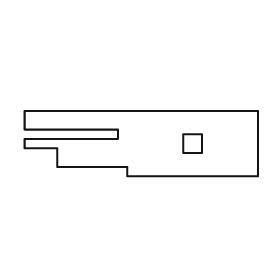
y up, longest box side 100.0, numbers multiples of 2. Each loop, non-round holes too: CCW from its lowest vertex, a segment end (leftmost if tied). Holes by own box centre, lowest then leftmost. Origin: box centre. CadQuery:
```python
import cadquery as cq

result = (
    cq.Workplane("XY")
    .moveTo(-6.0, -14.0)
    .lineTo(50.0, -14.0)
    .lineTo(50.0, 14.0)
    .lineTo(-50.0, 14.0)
    .lineTo(-50.0, 6.0)
    .lineTo(-10.0, 6.0)
    .lineTo(-10.0, 2.0)
    .lineTo(-50.0, 2.0)
    .lineTo(-50.0, -2.0)
    .lineTo(-36.0, -2.0)
    .lineTo(-36.0, -10.0)
    .lineTo(-6.0, -10.0)
    .close()
    .moveTo(18.0, -4.0)
    .lineTo(26.0, -4.0)
    .lineTo(26.0, 4.0)
    .lineTo(18.0, 4.0)
    .close()
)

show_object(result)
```